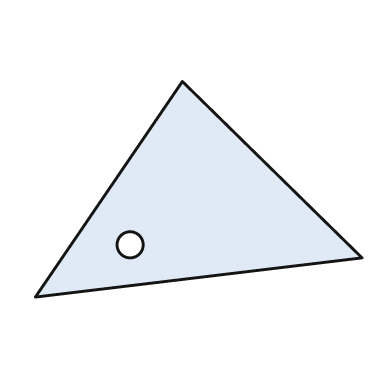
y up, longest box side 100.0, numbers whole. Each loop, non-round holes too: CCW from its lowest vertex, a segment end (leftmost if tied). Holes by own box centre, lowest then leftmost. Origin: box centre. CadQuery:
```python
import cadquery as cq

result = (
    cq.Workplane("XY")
    .moveTo(-50.0, -33.0)
    .lineTo(50.0, -21.0)
    .lineTo(-5.0, 33.0)
    .close()
    .moveTo(-21.0, -17.0)
    .circle(4.0)
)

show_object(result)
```